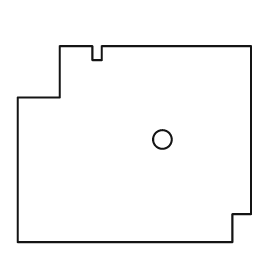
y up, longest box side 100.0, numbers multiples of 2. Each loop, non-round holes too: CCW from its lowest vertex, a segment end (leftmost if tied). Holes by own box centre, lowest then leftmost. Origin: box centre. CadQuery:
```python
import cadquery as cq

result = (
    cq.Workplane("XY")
    .moveTo(-50.0, -42.0)
    .lineTo(42.0, -42.0)
    .lineTo(42.0, -30.0)
    .lineTo(50.0, -30.0)
    .lineTo(50.0, 42.0)
    .lineTo(-14.0, 42.0)
    .lineTo(-14.0, 36.0)
    .lineTo(-18.0, 36.0)
    .lineTo(-18.0, 42.0)
    .lineTo(-32.0, 42.0)
    .lineTo(-32.0, 20.0)
    .lineTo(-50.0, 20.0)
    .close()
    .moveTo(12.0, 2.0)
    .circle(4.0)
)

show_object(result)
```